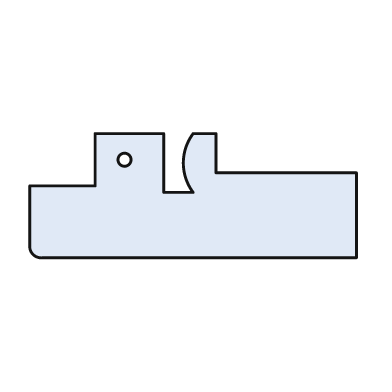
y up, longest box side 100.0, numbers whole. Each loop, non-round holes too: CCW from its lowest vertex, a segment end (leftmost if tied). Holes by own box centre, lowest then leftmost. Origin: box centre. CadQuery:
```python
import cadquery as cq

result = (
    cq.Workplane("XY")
    .moveTo(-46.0, -19.0)
    .lineTo(50.0, -19.0)
    .lineTo(50.0, 7.0)
    .lineTo(7.0, 7.0)
    .lineTo(7.0, 19.0)
    .lineTo(0.0, 19.0)
    .threePointArc((-3.0, 10.0), (0.0, 1.0))
    .lineTo(-9.0, 1.0)
    .lineTo(-9.0, 19.0)
    .lineTo(-30.0, 19.0)
    .lineTo(-30.0, 3.0)
    .lineTo(-50.0, 3.0)
    .lineTo(-50.0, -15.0)
    .threePointArc((-49.0, -18.0), (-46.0, -19.0))
    .close()
    .moveTo(-21.0, 11.0)
    .circle(2.0)
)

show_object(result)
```